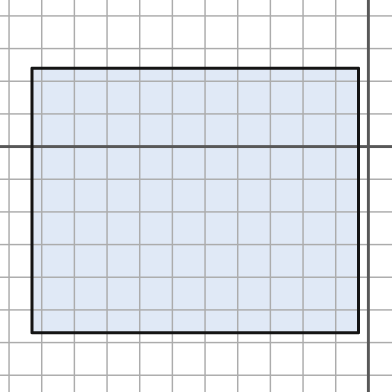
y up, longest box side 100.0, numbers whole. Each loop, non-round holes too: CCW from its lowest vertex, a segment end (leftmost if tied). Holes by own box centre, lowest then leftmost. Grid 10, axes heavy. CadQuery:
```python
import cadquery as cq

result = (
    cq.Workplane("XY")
    .moveTo(-103.0, -57.0)
    .lineTo(-3.0, -57.0)
    .lineTo(-3.0, 24.0)
    .lineTo(-103.0, 24.0)
    .close()
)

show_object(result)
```